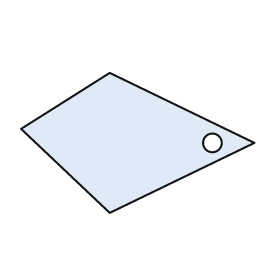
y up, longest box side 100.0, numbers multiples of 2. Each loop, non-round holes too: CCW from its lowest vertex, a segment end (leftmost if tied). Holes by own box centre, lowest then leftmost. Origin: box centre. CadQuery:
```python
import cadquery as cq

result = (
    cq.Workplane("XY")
    .moveTo(-12.0, -30.0)
    .lineTo(50.0, 0.0)
    .lineTo(-12.0, 30.0)
    .lineTo(-50.0, 6.0)
    .close()
    .moveTo(32.0, 0.0)
    .circle(4.0)
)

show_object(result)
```